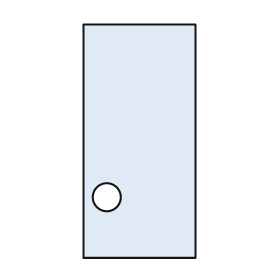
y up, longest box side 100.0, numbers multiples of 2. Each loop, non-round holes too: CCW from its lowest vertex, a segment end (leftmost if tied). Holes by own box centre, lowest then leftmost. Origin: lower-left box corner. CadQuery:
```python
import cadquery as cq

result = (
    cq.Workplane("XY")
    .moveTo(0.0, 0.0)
    .lineTo(48.0, 0.0)
    .lineTo(48.0, 100.0)
    .lineTo(0.0, 100.0)
    .close()
    .moveTo(10.0, 26.0)
    .circle(6.0)
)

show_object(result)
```